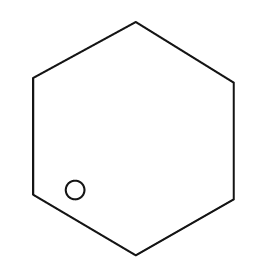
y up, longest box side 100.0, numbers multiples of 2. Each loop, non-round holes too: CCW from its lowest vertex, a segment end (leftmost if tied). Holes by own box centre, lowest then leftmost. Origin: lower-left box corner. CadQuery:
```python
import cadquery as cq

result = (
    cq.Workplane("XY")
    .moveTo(44.0, 0.0)
    .lineTo(86.0, 24.0)
    .lineTo(86.0, 74.0)
    .lineTo(44.0, 100.0)
    .lineTo(0.0, 76.0)
    .lineTo(0.0, 26.0)
    .close()
    .moveTo(18.0, 28.0)
    .circle(4.0)
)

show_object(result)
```